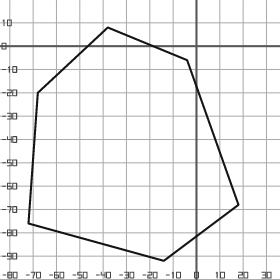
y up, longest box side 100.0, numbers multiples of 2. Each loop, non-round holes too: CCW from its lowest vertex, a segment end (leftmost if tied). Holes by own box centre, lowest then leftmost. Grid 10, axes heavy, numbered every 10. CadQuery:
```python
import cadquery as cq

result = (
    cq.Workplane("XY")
    .moveTo(-14.0, -92.0)
    .lineTo(18.0, -68.0)
    .lineTo(-4.0, -6.0)
    .lineTo(-38.0, 8.0)
    .lineTo(-68.0, -20.0)
    .lineTo(-72.0, -76.0)
    .close()
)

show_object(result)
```